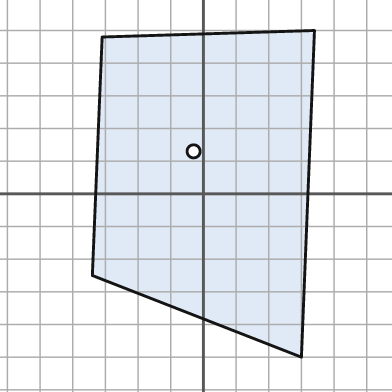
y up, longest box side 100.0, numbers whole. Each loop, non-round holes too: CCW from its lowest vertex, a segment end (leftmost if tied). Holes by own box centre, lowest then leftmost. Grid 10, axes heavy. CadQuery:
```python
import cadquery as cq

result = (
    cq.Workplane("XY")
    .moveTo(30.0, -50.0)
    .lineTo(34.0, 50.0)
    .lineTo(-31.0, 48.0)
    .lineTo(-34.0, -25.0)
    .close()
    .moveTo(-3.0, 13.0)
    .circle(2.0)
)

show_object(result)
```